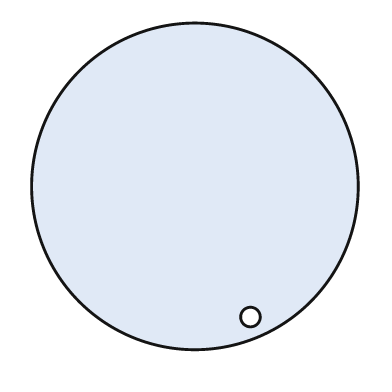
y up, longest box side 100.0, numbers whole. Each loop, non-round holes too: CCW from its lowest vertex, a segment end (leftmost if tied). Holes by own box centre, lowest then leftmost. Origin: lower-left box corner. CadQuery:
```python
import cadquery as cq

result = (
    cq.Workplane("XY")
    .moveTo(50.0, 50.0)
    .circle(50.0)
    .moveTo(67.0, 10.0)
    .circle(3.0)
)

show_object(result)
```